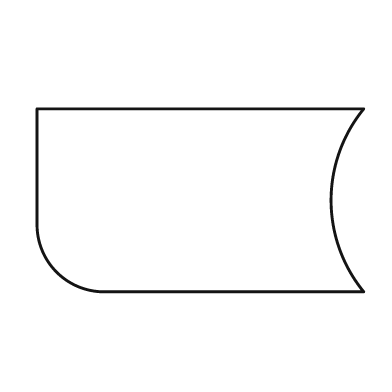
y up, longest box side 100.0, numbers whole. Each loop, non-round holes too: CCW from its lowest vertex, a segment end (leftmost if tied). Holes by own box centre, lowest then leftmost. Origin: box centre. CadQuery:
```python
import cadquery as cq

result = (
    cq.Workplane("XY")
    .moveTo(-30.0, -28.0)
    .lineTo(50.0, -28.0)
    .threePointArc((40.0, 0.0), (50.0, 28.0))
    .lineTo(-50.0, 28.0)
    .lineTo(-50.0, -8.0)
    .threePointArc((-44.0, -22.0), (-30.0, -28.0))
    .close()
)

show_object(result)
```